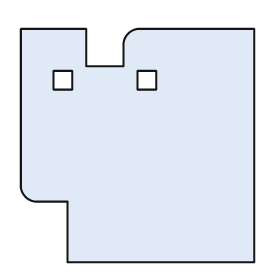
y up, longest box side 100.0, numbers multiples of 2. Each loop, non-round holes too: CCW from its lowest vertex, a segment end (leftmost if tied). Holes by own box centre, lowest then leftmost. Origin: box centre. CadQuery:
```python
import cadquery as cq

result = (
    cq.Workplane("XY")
    .moveTo(-30.0, -50.0)
    .lineTo(50.0, -50.0)
    .lineTo(50.0, 50.0)
    .lineTo(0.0, 50.0)
    .threePointArc((-4.0, 48.0), (-6.0, 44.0))
    .lineTo(-6.0, 34.0)
    .lineTo(-22.0, 34.0)
    .lineTo(-22.0, 50.0)
    .lineTo(-50.0, 50.0)
    .lineTo(-50.0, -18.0)
    .threePointArc((-48.0, -22.0), (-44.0, -24.0))
    .lineTo(-30.0, -24.0)
    .close()
    .moveTo(-36.0, 24.0)
    .lineTo(-28.0, 24.0)
    .lineTo(-28.0, 32.0)
    .lineTo(-36.0, 32.0)
    .close()
    .moveTo(0.0, 24.0)
    .lineTo(8.0, 24.0)
    .lineTo(8.0, 32.0)
    .lineTo(0.0, 32.0)
    .close()
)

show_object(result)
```